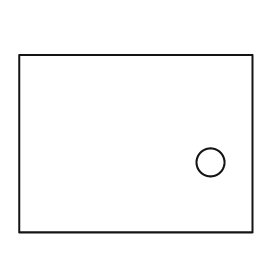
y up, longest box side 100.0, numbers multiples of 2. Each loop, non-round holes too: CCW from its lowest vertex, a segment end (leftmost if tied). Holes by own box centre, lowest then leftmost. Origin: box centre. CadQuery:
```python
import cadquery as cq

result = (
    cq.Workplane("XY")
    .moveTo(-50.0, -38.0)
    .lineTo(50.0, -38.0)
    .lineTo(50.0, 38.0)
    .lineTo(-50.0, 38.0)
    .close()
    .moveTo(32.0, -8.0)
    .circle(6.0)
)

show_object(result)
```